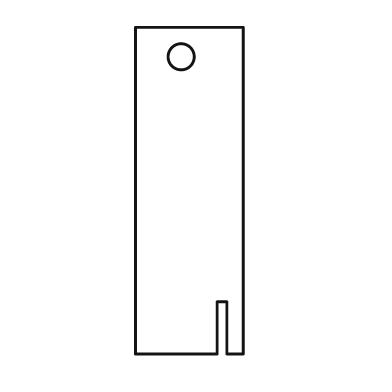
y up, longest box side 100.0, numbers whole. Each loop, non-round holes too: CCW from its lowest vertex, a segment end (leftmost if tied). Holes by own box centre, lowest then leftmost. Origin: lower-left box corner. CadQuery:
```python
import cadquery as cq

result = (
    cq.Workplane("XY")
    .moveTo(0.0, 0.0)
    .lineTo(25.0, 0.0)
    .lineTo(25.0, 16.0)
    .lineTo(28.0, 16.0)
    .lineTo(28.0, 0.0)
    .lineTo(33.0, 0.0)
    .lineTo(33.0, 100.0)
    .lineTo(0.0, 100.0)
    .close()
    .moveTo(14.0, 91.0)
    .circle(4.0)
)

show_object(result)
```